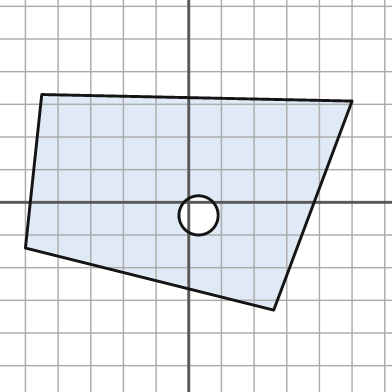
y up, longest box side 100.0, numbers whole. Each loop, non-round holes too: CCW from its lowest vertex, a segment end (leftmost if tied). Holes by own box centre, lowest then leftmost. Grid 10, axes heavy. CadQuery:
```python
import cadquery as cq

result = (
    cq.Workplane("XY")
    .moveTo(26.0, -33.0)
    .lineTo(50.0, 31.0)
    .lineTo(-45.0, 33.0)
    .lineTo(-50.0, -14.0)
    .close()
    .moveTo(3.0, -4.0)
    .circle(6.0)
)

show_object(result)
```